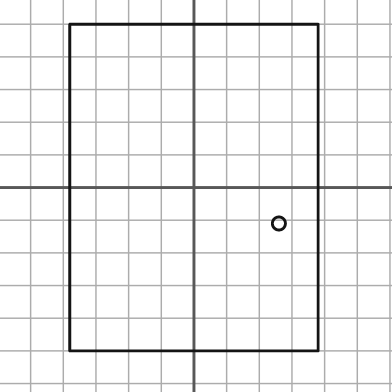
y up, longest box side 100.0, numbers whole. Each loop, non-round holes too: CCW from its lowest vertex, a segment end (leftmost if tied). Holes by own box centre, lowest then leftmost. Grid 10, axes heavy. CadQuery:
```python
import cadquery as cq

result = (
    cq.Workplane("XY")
    .moveTo(-38.0, -50.0)
    .lineTo(38.0, -50.0)
    .lineTo(38.0, 50.0)
    .lineTo(-38.0, 50.0)
    .close()
    .moveTo(26.0, -11.0)
    .circle(2.0)
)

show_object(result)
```